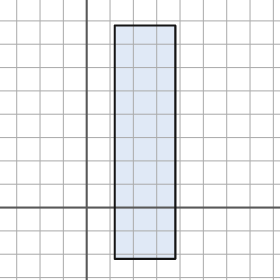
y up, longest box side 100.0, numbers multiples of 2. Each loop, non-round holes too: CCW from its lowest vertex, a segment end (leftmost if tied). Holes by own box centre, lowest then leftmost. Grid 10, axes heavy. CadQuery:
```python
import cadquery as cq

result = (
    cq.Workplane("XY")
    .moveTo(12.0, -22.0)
    .lineTo(38.0, -22.0)
    .lineTo(38.0, 78.0)
    .lineTo(12.0, 78.0)
    .close()
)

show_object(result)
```